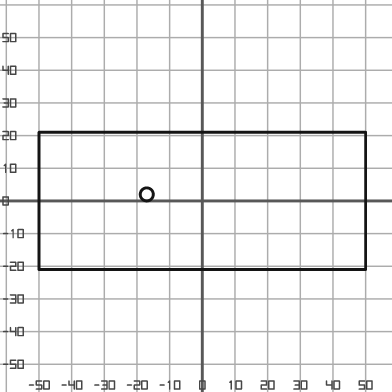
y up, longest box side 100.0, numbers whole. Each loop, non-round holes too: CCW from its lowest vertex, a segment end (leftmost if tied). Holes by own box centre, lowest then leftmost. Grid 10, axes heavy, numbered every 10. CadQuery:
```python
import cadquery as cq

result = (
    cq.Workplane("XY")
    .moveTo(-50.0, -21.0)
    .lineTo(50.0, -21.0)
    .lineTo(50.0, 21.0)
    .lineTo(-50.0, 21.0)
    .close()
    .moveTo(-17.0, 2.0)
    .circle(2.0)
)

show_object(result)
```